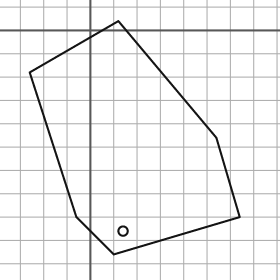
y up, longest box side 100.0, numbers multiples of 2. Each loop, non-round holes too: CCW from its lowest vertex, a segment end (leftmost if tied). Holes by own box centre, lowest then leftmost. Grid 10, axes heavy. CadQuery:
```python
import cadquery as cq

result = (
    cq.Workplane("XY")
    .moveTo(10.0, -96.0)
    .lineTo(64.0, -80.0)
    .lineTo(54.0, -46.0)
    .lineTo(12.0, 4.0)
    .lineTo(-26.0, -18.0)
    .lineTo(-6.0, -80.0)
    .close()
    .moveTo(14.0, -86.0)
    .circle(2.0)
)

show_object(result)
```